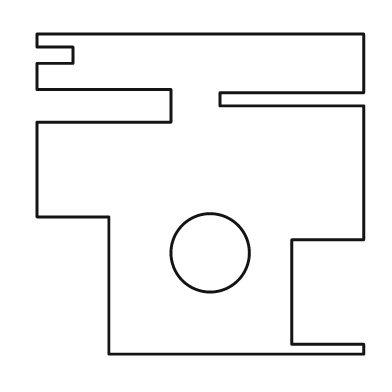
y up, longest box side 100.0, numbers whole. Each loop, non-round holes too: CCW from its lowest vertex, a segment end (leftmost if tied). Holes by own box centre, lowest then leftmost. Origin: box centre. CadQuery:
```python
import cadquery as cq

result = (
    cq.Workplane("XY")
    .moveTo(-28.0, -49.0)
    .lineTo(50.0, -49.0)
    .lineTo(50.0, -46.0)
    .lineTo(28.0, -46.0)
    .lineTo(28.0, -14.0)
    .lineTo(50.0, -14.0)
    .lineTo(50.0, 27.0)
    .lineTo(6.0, 27.0)
    .lineTo(6.0, 31.0)
    .lineTo(50.0, 31.0)
    .lineTo(50.0, 49.0)
    .lineTo(-50.0, 49.0)
    .lineTo(-50.0, 45.0)
    .lineTo(-39.0, 45.0)
    .lineTo(-39.0, 40.0)
    .lineTo(-50.0, 40.0)
    .lineTo(-50.0, 32.0)
    .lineTo(-9.0, 32.0)
    .lineTo(-9.0, 22.0)
    .lineTo(-50.0, 22.0)
    .lineTo(-50.0, -7.0)
    .lineTo(-28.0, -7.0)
    .close()
    .moveTo(3.0, -18.0)
    .circle(12.0)
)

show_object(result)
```